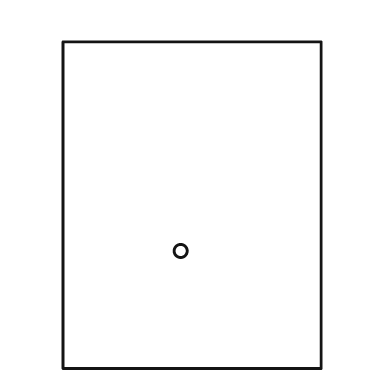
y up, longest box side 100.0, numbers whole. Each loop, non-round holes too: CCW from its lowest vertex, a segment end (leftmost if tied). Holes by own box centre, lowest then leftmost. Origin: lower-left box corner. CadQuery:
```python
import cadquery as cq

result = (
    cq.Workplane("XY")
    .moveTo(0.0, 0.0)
    .lineTo(79.0, 0.0)
    .lineTo(79.0, 100.0)
    .lineTo(0.0, 100.0)
    .close()
    .moveTo(36.0, 36.0)
    .circle(2.0)
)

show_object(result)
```